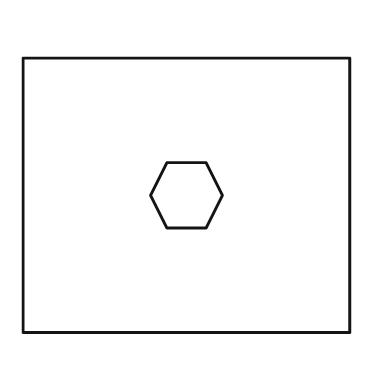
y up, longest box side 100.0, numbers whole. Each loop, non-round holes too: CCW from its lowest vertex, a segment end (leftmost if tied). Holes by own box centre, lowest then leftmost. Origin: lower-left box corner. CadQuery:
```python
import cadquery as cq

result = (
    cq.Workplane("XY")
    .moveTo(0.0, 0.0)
    .lineTo(100.0, 0.0)
    .lineTo(100.0, 84.0)
    .lineTo(0.0, 84.0)
    .close()
    .moveTo(44.0, 32.0)
    .lineTo(56.0, 32.0)
    .lineTo(61.0, 42.0)
    .lineTo(56.0, 52.0)
    .lineTo(44.0, 52.0)
    .lineTo(39.0, 42.0)
    .close()
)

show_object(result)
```